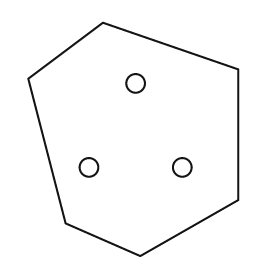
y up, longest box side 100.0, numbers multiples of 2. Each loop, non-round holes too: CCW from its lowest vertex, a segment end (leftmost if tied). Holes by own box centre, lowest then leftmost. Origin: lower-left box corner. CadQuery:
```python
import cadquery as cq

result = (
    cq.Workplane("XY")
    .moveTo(48.0, 0.0)
    .lineTo(90.0, 24.0)
    .lineTo(90.0, 80.0)
    .lineTo(32.0, 100.0)
    .lineTo(0.0, 76.0)
    .lineTo(16.0, 14.0)
    .close()
    .moveTo(26.0, 38.0)
    .circle(4.0)
    .moveTo(66.0, 38.0)
    .circle(4.0)
    .moveTo(46.0, 74.0)
    .circle(4.0)
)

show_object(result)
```